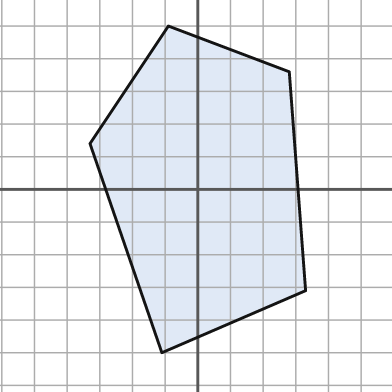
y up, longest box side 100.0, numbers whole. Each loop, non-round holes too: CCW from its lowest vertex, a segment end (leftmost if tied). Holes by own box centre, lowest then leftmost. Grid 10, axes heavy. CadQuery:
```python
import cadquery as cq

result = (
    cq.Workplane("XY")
    .moveTo(-11.0, -50.0)
    .lineTo(33.0, -31.0)
    .lineTo(28.0, 36.0)
    .lineTo(-9.0, 50.0)
    .lineTo(-33.0, 14.0)
    .close()
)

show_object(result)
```